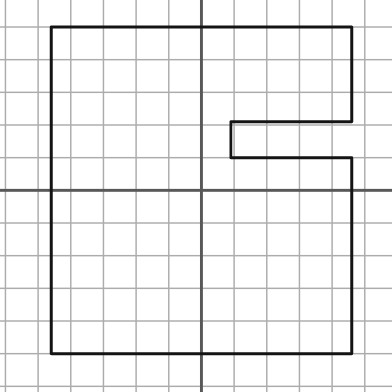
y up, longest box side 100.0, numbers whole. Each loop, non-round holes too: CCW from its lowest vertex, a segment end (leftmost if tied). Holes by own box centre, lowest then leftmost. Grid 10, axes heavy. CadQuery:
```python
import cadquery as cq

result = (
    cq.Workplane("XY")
    .moveTo(-46.0, -50.0)
    .lineTo(46.0, -50.0)
    .lineTo(46.0, 10.0)
    .lineTo(9.0, 10.0)
    .lineTo(9.0, 21.0)
    .lineTo(46.0, 21.0)
    .lineTo(46.0, 50.0)
    .lineTo(-46.0, 50.0)
    .close()
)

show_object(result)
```